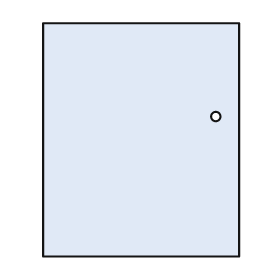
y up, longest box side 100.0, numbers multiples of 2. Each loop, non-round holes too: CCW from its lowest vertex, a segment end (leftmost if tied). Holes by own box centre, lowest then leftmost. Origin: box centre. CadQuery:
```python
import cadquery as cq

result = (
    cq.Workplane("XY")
    .moveTo(-42.0, -50.0)
    .lineTo(42.0, -50.0)
    .lineTo(42.0, 50.0)
    .lineTo(-42.0, 50.0)
    .close()
    .moveTo(32.0, 10.0)
    .circle(2.0)
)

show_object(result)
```